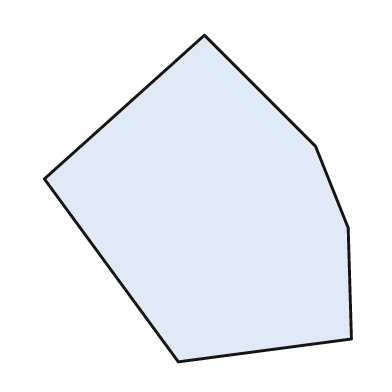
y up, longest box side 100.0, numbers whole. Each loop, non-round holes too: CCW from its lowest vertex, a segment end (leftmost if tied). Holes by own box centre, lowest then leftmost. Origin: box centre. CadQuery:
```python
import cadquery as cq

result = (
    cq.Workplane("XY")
    .moveTo(-6.0, -50.0)
    .lineTo(47.0, -43.0)
    .lineTo(46.0, -9.0)
    .lineTo(36.0, 16.0)
    .lineTo(2.0, 50.0)
    .lineTo(-47.0, 6.0)
    .close()
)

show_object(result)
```